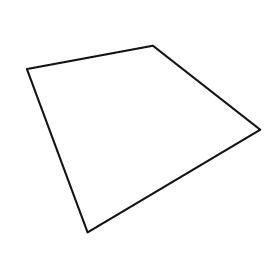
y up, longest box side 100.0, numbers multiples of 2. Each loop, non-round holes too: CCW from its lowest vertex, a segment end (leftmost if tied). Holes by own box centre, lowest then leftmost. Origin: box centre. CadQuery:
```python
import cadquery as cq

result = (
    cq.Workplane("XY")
    .moveTo(-24.0, -40.0)
    .lineTo(50.0, 4.0)
    .lineTo(4.0, 40.0)
    .lineTo(-50.0, 30.0)
    .close()
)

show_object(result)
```